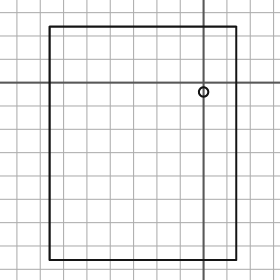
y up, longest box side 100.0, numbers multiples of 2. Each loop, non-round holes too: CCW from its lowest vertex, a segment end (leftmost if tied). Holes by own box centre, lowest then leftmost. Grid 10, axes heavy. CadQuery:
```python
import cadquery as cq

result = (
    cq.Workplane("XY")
    .moveTo(-66.0, -76.0)
    .lineTo(14.0, -76.0)
    .lineTo(14.0, 24.0)
    .lineTo(-66.0, 24.0)
    .close()
    .moveTo(0.0, -4.0)
    .circle(2.0)
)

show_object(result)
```